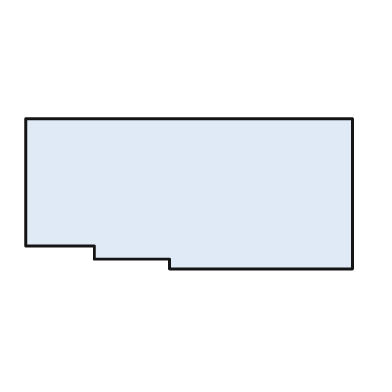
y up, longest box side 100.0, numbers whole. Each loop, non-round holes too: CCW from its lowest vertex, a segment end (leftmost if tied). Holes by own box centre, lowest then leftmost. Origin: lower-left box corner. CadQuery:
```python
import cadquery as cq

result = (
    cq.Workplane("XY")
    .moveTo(44.0, 0.0)
    .lineTo(100.0, 0.0)
    .lineTo(100.0, 46.0)
    .lineTo(0.0, 46.0)
    .lineTo(0.0, 7.0)
    .lineTo(21.0, 7.0)
    .lineTo(21.0, 3.0)
    .lineTo(44.0, 3.0)
    .close()
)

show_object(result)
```